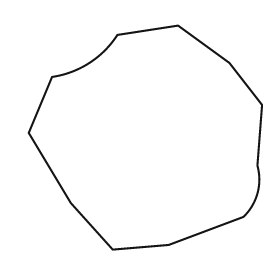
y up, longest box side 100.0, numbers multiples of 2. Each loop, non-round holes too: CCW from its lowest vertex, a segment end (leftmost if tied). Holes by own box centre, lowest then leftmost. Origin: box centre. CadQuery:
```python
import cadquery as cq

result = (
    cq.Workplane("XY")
    .moveTo(-14.0, -48.0)
    .lineTo(10.0, -46.0)
    .lineTo(42.0, -34.0)
    .threePointArc((48.0, -24.0), (48.0, -12.0))
    .lineTo(50.0, 14.0)
    .lineTo(36.0, 32.0)
    .lineTo(14.0, 48.0)
    .lineTo(-12.0, 44.0)
    .threePointArc((-24.0, 32.0), (-40.0, 26.0))
    .lineTo(-50.0, 2.0)
    .lineTo(-32.0, -28.0)
    .close()
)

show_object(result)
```